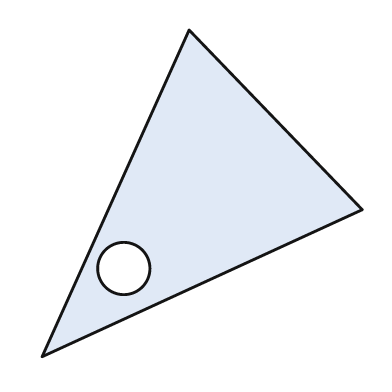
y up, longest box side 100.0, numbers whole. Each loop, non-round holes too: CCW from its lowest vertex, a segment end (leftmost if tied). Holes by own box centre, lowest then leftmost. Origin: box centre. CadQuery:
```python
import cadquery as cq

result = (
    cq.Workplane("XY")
    .moveTo(-49.0, -50.0)
    .lineTo(49.0, -5.0)
    .lineTo(-4.0, 50.0)
    .close()
    .moveTo(-24.0, -23.0)
    .circle(8.0)
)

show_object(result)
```